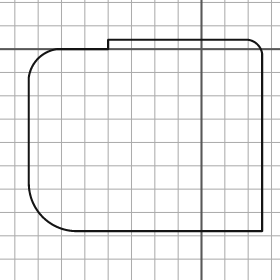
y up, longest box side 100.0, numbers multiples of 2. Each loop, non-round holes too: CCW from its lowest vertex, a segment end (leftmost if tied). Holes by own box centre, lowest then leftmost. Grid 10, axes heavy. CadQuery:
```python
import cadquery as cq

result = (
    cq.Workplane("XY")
    .moveTo(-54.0, -78.0)
    .lineTo(26.0, -78.0)
    .lineTo(26.0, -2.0)
    .threePointArc((24.0, 2.0), (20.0, 4.0))
    .lineTo(-40.0, 4.0)
    .lineTo(-40.0, 0.0)
    .lineTo(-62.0, 0.0)
    .threePointArc((-70.0, -4.0), (-74.0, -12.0))
    .lineTo(-74.0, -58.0)
    .threePointArc((-68.0, -72.0), (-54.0, -78.0))
    .close()
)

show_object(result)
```